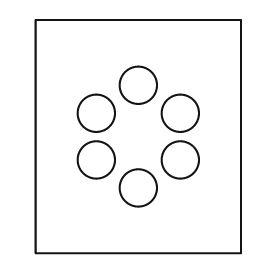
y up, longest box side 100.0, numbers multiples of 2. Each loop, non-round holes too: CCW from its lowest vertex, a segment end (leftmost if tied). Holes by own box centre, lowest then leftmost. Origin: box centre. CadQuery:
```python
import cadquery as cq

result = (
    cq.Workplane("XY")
    .moveTo(-44.0, -50.0)
    .lineTo(44.0, -50.0)
    .lineTo(44.0, 50.0)
    .lineTo(-44.0, 50.0)
    .close()
    .moveTo(0.0, -22.0)
    .circle(8.0)
    .moveTo(-18.0, -10.0)
    .circle(8.0)
    .moveTo(18.0, -10.0)
    .circle(8.0)
    .moveTo(-18.0, 10.0)
    .circle(8.0)
    .moveTo(18.0, 10.0)
    .circle(8.0)
    .moveTo(0.0, 22.0)
    .circle(8.0)
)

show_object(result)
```